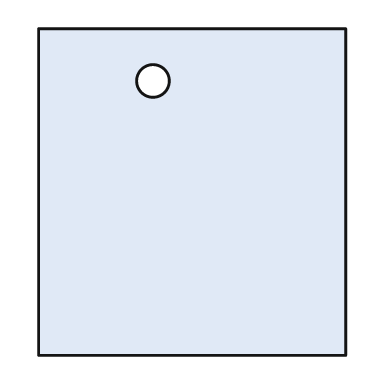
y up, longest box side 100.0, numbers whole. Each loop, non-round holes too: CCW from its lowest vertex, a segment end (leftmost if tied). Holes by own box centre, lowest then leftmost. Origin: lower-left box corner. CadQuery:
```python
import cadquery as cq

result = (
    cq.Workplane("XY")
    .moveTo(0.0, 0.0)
    .lineTo(94.0, 0.0)
    .lineTo(94.0, 100.0)
    .lineTo(0.0, 100.0)
    .close()
    .moveTo(35.0, 84.0)
    .circle(5.0)
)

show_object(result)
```